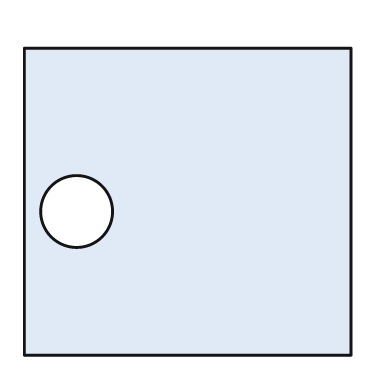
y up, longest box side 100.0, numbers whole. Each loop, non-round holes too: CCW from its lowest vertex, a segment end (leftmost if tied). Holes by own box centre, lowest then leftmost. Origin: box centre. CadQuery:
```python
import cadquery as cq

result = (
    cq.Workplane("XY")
    .moveTo(-50.0, -47.0)
    .lineTo(50.0, -47.0)
    .lineTo(50.0, 47.0)
    .lineTo(-50.0, 47.0)
    .close()
    .moveTo(-34.0, -3.0)
    .circle(11.0)
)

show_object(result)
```